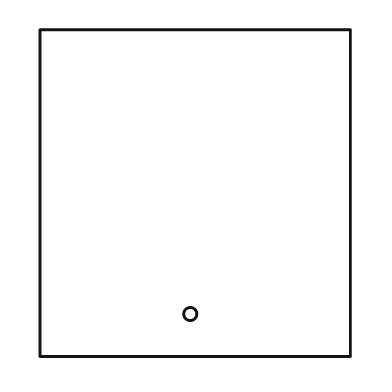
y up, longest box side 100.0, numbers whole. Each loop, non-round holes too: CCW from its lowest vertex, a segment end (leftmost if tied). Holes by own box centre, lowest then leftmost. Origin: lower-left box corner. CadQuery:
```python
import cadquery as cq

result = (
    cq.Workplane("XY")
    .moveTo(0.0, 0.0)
    .lineTo(95.0, 0.0)
    .lineTo(95.0, 100.0)
    .lineTo(0.0, 100.0)
    .close()
    .moveTo(46.0, 13.0)
    .circle(2.0)
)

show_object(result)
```